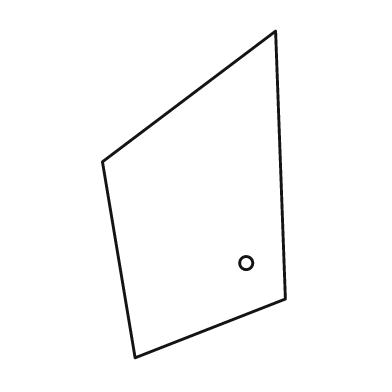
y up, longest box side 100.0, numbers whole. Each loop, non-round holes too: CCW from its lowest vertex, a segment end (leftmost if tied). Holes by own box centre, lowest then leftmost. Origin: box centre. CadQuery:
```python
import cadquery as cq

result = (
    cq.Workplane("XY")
    .moveTo(-18.0, -50.0)
    .lineTo(28.0, -32.0)
    .lineTo(25.0, 50.0)
    .lineTo(-28.0, 10.0)
    .close()
    .moveTo(16.0, -21.0)
    .circle(2.0)
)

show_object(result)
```